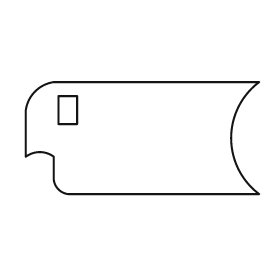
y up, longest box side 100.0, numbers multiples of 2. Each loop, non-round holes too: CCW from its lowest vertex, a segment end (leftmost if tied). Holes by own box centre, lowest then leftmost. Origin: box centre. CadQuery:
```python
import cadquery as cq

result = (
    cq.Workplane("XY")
    .moveTo(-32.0, -24.0)
    .lineTo(50.0, -24.0)
    .threePointArc((38.0, 0.0), (50.0, 24.0))
    .lineTo(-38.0, 24.0)
    .threePointArc((-46.0, 20.0), (-50.0, 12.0))
    .lineTo(-50.0, -8.0)
    .threePointArc((-44.0, -6.0), (-38.0, -8.0))
    .lineTo(-38.0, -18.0)
    .threePointArc((-36.0, -22.0), (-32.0, -24.0))
    .close()
    .moveTo(-36.0, 6.0)
    .lineTo(-28.0, 6.0)
    .lineTo(-28.0, 18.0)
    .lineTo(-36.0, 18.0)
    .close()
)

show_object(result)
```